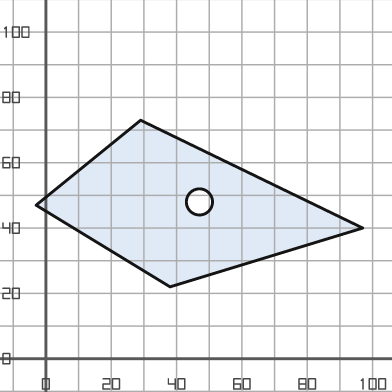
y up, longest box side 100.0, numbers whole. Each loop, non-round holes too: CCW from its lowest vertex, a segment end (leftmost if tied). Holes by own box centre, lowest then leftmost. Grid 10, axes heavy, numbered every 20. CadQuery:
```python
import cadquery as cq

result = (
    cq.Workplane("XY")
    .moveTo(38.0, 22.0)
    .lineTo(97.0, 40.0)
    .lineTo(29.0, 73.0)
    .lineTo(-3.0, 47.0)
    .close()
    .moveTo(47.0, 48.0)
    .circle(4.0)
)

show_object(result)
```